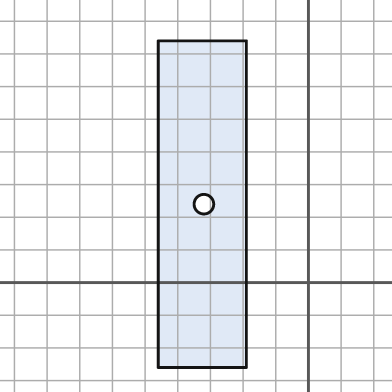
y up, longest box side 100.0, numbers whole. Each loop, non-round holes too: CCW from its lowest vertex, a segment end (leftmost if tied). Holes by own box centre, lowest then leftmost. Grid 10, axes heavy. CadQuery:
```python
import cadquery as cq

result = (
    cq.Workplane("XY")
    .moveTo(-46.0, -26.0)
    .lineTo(-19.0, -26.0)
    .lineTo(-19.0, 74.0)
    .lineTo(-46.0, 74.0)
    .close()
    .moveTo(-32.0, 24.0)
    .circle(3.0)
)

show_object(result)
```